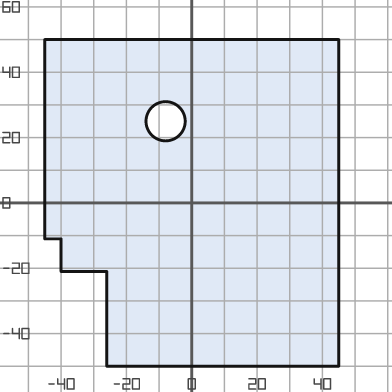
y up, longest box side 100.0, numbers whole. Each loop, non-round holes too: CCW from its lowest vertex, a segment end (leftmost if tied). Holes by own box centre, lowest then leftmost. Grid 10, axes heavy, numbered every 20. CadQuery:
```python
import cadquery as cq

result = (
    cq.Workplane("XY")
    .moveTo(-26.0, -50.0)
    .lineTo(45.0, -50.0)
    .lineTo(45.0, 50.0)
    .lineTo(-45.0, 50.0)
    .lineTo(-45.0, -11.0)
    .lineTo(-40.0, -11.0)
    .lineTo(-40.0, -21.0)
    .lineTo(-26.0, -21.0)
    .close()
    .moveTo(-8.0, 25.0)
    .circle(6.0)
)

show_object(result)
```